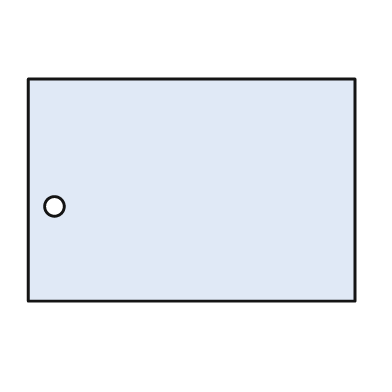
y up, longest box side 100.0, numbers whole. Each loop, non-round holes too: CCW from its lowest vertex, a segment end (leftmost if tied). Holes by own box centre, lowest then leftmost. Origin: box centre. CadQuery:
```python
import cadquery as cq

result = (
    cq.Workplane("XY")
    .moveTo(-50.0, -34.0)
    .lineTo(50.0, -34.0)
    .lineTo(50.0, 34.0)
    .lineTo(-50.0, 34.0)
    .close()
    .moveTo(-42.0, -5.0)
    .circle(3.0)
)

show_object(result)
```